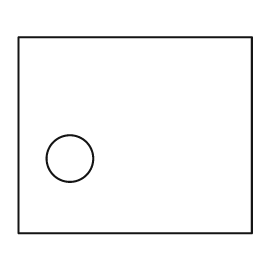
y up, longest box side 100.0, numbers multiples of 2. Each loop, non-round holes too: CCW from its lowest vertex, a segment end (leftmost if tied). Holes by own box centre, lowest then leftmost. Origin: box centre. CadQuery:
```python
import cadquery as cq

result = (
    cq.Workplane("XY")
    .moveTo(-50.0, -42.0)
    .lineTo(50.0, -42.0)
    .lineTo(50.0, 42.0)
    .lineTo(-50.0, 42.0)
    .close()
    .moveTo(-28.0, -10.0)
    .circle(10.0)
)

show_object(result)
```